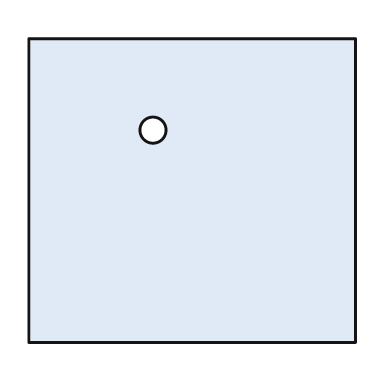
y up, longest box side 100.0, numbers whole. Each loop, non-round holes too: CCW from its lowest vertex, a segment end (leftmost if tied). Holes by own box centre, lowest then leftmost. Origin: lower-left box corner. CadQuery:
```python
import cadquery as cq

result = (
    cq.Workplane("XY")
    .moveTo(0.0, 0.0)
    .lineTo(100.0, 0.0)
    .lineTo(100.0, 93.0)
    .lineTo(0.0, 93.0)
    .close()
    .moveTo(38.0, 65.0)
    .circle(4.0)
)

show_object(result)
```